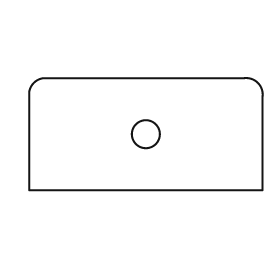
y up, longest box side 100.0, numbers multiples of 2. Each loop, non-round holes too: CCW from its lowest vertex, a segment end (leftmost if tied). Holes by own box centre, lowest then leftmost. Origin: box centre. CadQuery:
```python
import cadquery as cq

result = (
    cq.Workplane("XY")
    .moveTo(-50.0, -24.0)
    .lineTo(50.0, -24.0)
    .lineTo(50.0, 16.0)
    .threePointArc((48.0, 22.0), (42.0, 24.0))
    .lineTo(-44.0, 24.0)
    .threePointArc((-48.0, 22.0), (-50.0, 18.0))
    .close()
    .moveTo(0.0, 0.0)
    .circle(6.0)
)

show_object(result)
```